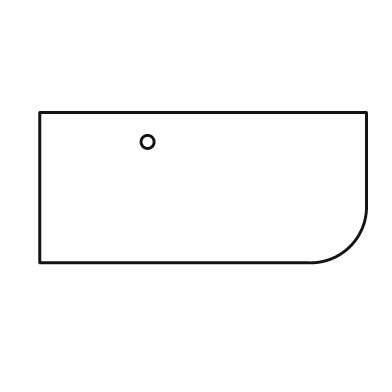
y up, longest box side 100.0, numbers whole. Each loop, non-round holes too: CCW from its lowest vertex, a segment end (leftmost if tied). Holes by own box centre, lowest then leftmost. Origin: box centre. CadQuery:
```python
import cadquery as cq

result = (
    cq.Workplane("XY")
    .moveTo(-50.0, -23.0)
    .lineTo(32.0, -23.0)
    .threePointArc((45.0, -18.0), (50.0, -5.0))
    .lineTo(50.0, 23.0)
    .lineTo(-50.0, 23.0)
    .close()
    .moveTo(-17.0, 14.0)
    .circle(2.0)
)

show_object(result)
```